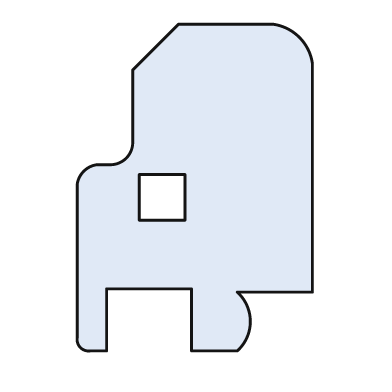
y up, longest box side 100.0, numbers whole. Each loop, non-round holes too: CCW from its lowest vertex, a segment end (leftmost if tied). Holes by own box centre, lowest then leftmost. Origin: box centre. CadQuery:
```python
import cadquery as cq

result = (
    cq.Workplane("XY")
    .moveTo(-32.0, -50.0)
    .lineTo(-27.0, -50.0)
    .lineTo(-27.0, -31.0)
    .lineTo(-1.0, -31.0)
    .lineTo(-1.0, -50.0)
    .lineTo(13.0, -50.0)
    .threePointArc((17.0, -41.0), (13.0, -32.0))
    .lineTo(36.0, -32.0)
    .lineTo(36.0, 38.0)
    .threePointArc((32.0, 46.0), (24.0, 50.0))
    .lineTo(-5.0, 50.0)
    .lineTo(-19.0, 36.0)
    .lineTo(-19.0, 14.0)
    .threePointArc((-21.0, 9.0), (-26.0, 7.0))
    .lineTo(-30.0, 7.0)
    .threePointArc((-34.0, 5.0), (-36.0, 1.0))
    .lineTo(-36.0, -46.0)
    .threePointArc((-35.0, -49.0), (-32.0, -50.0))
    .close()
    .moveTo(-17.0, -10.0)
    .lineTo(-3.0, -10.0)
    .lineTo(-3.0, 4.0)
    .lineTo(-17.0, 4.0)
    .close()
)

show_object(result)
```